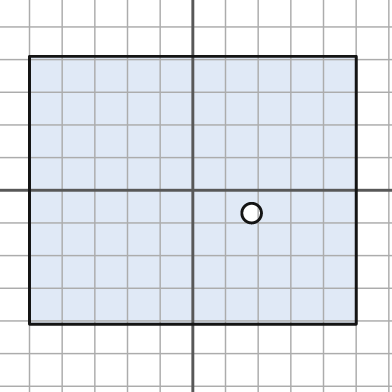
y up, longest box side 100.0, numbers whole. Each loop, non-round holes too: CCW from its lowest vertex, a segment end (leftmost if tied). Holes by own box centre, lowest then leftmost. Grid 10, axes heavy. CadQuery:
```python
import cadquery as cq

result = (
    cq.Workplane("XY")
    .moveTo(-50.0, -41.0)
    .lineTo(50.0, -41.0)
    .lineTo(50.0, 41.0)
    .lineTo(-50.0, 41.0)
    .close()
    .moveTo(18.0, -7.0)
    .circle(3.0)
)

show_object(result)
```